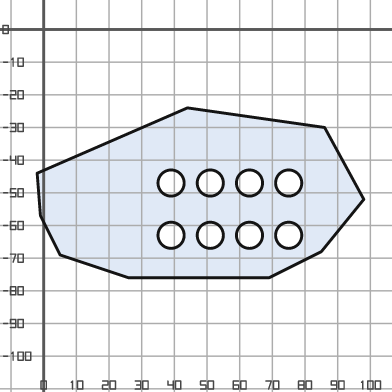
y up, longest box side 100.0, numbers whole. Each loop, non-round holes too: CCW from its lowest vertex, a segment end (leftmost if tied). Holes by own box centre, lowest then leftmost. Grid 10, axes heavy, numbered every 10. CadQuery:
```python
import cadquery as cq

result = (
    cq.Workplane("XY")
    .moveTo(26.0, -76.0)
    .lineTo(69.0, -76.0)
    .lineTo(85.0, -68.0)
    .lineTo(98.0, -52.0)
    .lineTo(86.0, -30.0)
    .lineTo(44.0, -24.0)
    .lineTo(-2.0, -44.0)
    .lineTo(-1.0, -57.0)
    .lineTo(5.0, -69.0)
    .close()
    .moveTo(39.0, -63.0)
    .circle(4.0)
    .moveTo(51.0, -63.0)
    .circle(4.0)
    .moveTo(63.0, -63.0)
    .circle(4.0)
    .moveTo(75.0, -63.0)
    .circle(4.0)
    .moveTo(39.0, -47.0)
    .circle(4.0)
    .moveTo(51.0, -47.0)
    .circle(4.0)
    .moveTo(63.0, -47.0)
    .circle(4.0)
    .moveTo(75.0, -47.0)
    .circle(4.0)
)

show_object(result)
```